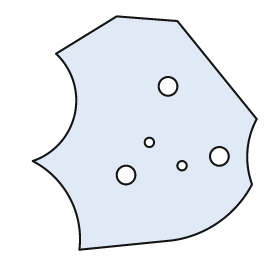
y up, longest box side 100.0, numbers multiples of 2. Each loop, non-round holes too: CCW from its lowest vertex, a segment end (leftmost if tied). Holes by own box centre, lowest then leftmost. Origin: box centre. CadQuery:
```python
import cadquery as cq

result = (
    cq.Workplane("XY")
    .moveTo(-28.0, -50.0)
    .lineTo(12.0, -46.0)
    .threePointArc((32.0, -38.0), (46.0, -22.0))
    .threePointArc((44.0, -8.0), (48.0, 6.0))
    .lineTo(14.0, 48.0)
    .lineTo(-12.0, 50.0)
    .lineTo(-38.0, 34.0)
    .threePointArc((-30.0, 8.0), (-48.0, -12.0))
    .threePointArc((-32.0, -28.0), (-28.0, -50.0))
    .close()
    .moveTo(-8.0, -18.0)
    .circle(4.0)
    .moveTo(16.0, -14.0)
    .circle(2.0)
    .moveTo(32.0, -10.0)
    .circle(4.0)
    .moveTo(2.0, -4.0)
    .circle(2.0)
    .moveTo(10.0, 20.0)
    .circle(4.0)
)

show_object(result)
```